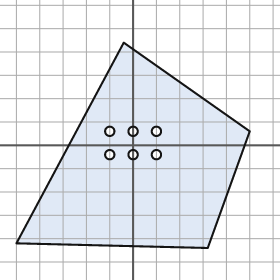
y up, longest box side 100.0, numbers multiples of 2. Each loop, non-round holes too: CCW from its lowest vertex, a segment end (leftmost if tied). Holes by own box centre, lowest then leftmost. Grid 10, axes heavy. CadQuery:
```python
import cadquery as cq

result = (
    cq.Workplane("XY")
    .moveTo(32.0, -44.0)
    .lineTo(50.0, 6.0)
    .lineTo(-4.0, 44.0)
    .lineTo(-50.0, -42.0)
    .close()
    .moveTo(-10.0, -4.0)
    .circle(2.0)
    .moveTo(0.0, -4.0)
    .circle(2.0)
    .moveTo(10.0, -4.0)
    .circle(2.0)
    .moveTo(-10.0, 6.0)
    .circle(2.0)
    .moveTo(0.0, 6.0)
    .circle(2.0)
    .moveTo(10.0, 6.0)
    .circle(2.0)
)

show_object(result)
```